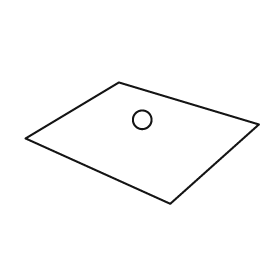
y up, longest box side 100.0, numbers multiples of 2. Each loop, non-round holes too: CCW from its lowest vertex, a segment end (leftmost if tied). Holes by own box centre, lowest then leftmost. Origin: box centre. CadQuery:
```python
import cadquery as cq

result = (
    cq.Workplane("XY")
    .moveTo(12.0, -26.0)
    .lineTo(50.0, 8.0)
    .lineTo(-10.0, 26.0)
    .lineTo(-50.0, 2.0)
    .close()
    .moveTo(0.0, 10.0)
    .circle(4.0)
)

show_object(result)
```